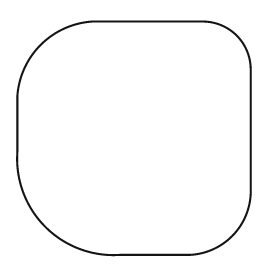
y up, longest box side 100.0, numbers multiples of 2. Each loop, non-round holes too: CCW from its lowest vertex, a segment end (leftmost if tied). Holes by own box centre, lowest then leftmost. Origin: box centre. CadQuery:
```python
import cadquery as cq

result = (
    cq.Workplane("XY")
    .moveTo(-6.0, -50.0)
    .lineTo(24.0, -50.0)
    .threePointArc((42.0, -42.0), (50.0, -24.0))
    .lineTo(50.0, 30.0)
    .threePointArc((44.0, 44.0), (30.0, 50.0))
    .lineTo(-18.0, 50.0)
    .threePointArc((-40.0, 40.0), (-50.0, 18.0))
    .lineTo(-50.0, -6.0)
    .threePointArc((-38.0, -38.0), (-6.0, -50.0))
    .close()
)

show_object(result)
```